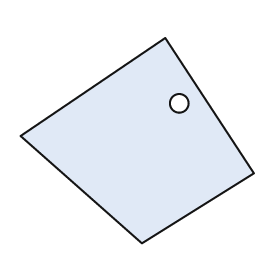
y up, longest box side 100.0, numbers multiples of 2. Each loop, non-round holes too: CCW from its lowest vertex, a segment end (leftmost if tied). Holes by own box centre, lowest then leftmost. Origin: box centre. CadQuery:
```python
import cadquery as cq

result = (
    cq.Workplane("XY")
    .moveTo(2.0, -44.0)
    .lineTo(50.0, -14.0)
    .lineTo(12.0, 44.0)
    .lineTo(-50.0, 2.0)
    .close()
    .moveTo(18.0, 16.0)
    .circle(4.0)
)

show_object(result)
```